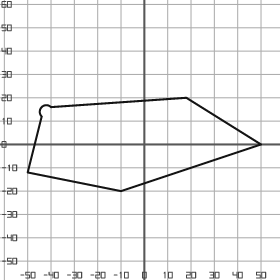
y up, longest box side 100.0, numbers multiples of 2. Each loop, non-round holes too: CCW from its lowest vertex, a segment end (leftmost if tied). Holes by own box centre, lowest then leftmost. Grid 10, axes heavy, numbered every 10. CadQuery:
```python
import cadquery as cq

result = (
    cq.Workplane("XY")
    .moveTo(-10.0, -20.0)
    .lineTo(50.0, 0.0)
    .lineTo(18.0, 20.0)
    .lineTo(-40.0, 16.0)
    .threePointArc((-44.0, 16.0), (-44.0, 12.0))
    .lineTo(-50.0, -12.0)
    .close()
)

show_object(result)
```